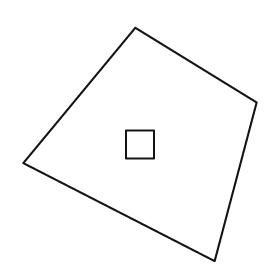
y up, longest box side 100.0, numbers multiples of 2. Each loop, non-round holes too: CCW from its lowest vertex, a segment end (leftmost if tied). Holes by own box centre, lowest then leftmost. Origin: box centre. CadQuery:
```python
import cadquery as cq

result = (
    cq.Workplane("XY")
    .moveTo(32.0, -50.0)
    .lineTo(50.0, 18.0)
    .lineTo(-2.0, 50.0)
    .lineTo(-50.0, -8.0)
    .close()
    .moveTo(-6.0, -6.0)
    .lineTo(6.0, -6.0)
    .lineTo(6.0, 6.0)
    .lineTo(-6.0, 6.0)
    .close()
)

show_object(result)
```